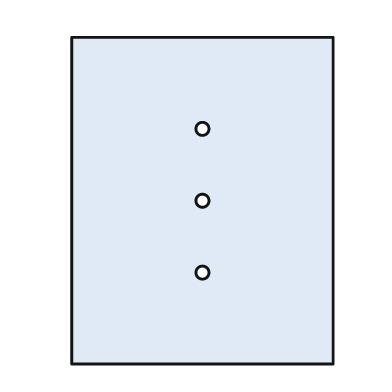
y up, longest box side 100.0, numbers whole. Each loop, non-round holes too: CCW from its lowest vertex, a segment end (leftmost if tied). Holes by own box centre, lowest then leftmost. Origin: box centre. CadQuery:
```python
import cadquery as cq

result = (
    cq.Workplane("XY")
    .moveTo(-40.0, -50.0)
    .lineTo(40.0, -50.0)
    .lineTo(40.0, 50.0)
    .lineTo(-40.0, 50.0)
    .close()
    .moveTo(0.0, -22.0)
    .circle(2.0)
    .moveTo(0.0, 0.0)
    .circle(2.0)
    .moveTo(0.0, 22.0)
    .circle(2.0)
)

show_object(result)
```